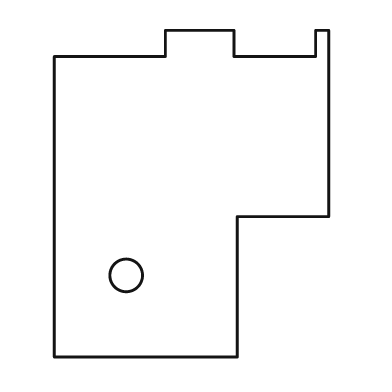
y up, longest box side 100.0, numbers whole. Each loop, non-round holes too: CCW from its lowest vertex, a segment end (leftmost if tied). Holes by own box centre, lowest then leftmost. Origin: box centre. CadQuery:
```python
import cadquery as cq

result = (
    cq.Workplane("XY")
    .moveTo(-42.0, -50.0)
    .lineTo(14.0, -50.0)
    .lineTo(14.0, -7.0)
    .lineTo(42.0, -7.0)
    .lineTo(42.0, 50.0)
    .lineTo(38.0, 50.0)
    .lineTo(38.0, 42.0)
    .lineTo(13.0, 42.0)
    .lineTo(13.0, 50.0)
    .lineTo(-8.0, 50.0)
    .lineTo(-8.0, 42.0)
    .lineTo(-42.0, 42.0)
    .close()
    .moveTo(-20.0, -25.0)
    .circle(5.0)
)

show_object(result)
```